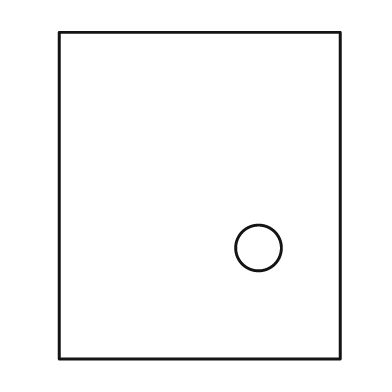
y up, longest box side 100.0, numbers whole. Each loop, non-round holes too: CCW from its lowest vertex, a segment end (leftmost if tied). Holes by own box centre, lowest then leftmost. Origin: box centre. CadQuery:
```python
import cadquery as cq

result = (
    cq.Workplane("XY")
    .moveTo(-43.0, -50.0)
    .lineTo(43.0, -50.0)
    .lineTo(43.0, 50.0)
    .lineTo(-43.0, 50.0)
    .close()
    .moveTo(18.0, -16.0)
    .circle(7.0)
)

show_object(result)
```